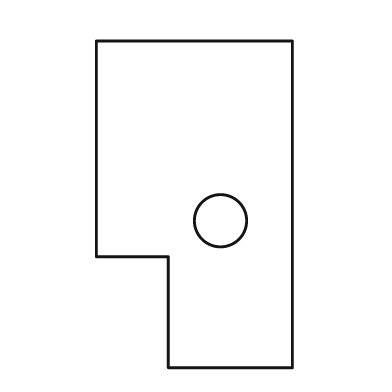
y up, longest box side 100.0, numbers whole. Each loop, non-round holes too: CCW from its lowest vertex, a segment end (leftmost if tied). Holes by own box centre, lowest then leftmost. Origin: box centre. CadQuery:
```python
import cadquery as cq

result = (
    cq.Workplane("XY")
    .moveTo(-8.0, -50.0)
    .lineTo(30.0, -50.0)
    .lineTo(30.0, 50.0)
    .lineTo(-30.0, 50.0)
    .lineTo(-30.0, -16.0)
    .lineTo(-8.0, -16.0)
    .close()
    .moveTo(8.0, -5.0)
    .circle(8.0)
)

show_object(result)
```